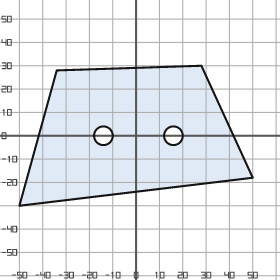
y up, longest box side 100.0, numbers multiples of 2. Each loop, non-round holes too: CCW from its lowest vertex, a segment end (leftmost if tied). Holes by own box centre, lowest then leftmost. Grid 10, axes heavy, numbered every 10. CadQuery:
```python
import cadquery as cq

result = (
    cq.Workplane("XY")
    .moveTo(-50.0, -30.0)
    .lineTo(50.0, -18.0)
    .lineTo(28.0, 30.0)
    .lineTo(-34.0, 28.0)
    .close()
    .moveTo(-14.0, 0.0)
    .circle(4.0)
    .moveTo(16.0, 0.0)
    .circle(4.0)
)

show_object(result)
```